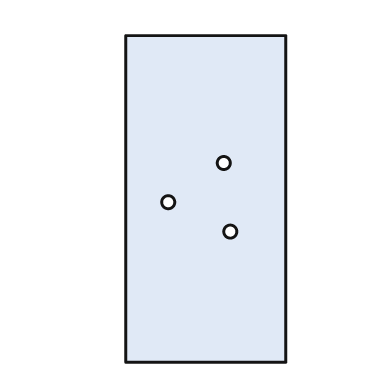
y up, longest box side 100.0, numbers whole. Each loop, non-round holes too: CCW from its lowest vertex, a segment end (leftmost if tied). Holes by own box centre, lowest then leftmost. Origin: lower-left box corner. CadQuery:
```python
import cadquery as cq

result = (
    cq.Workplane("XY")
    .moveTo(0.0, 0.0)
    .lineTo(49.0, 0.0)
    .lineTo(49.0, 100.0)
    .lineTo(0.0, 100.0)
    .close()
    .moveTo(32.0, 40.0)
    .circle(2.0)
    .moveTo(13.0, 49.0)
    .circle(2.0)
    .moveTo(30.0, 61.0)
    .circle(2.0)
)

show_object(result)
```